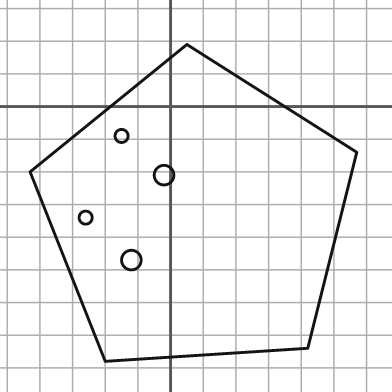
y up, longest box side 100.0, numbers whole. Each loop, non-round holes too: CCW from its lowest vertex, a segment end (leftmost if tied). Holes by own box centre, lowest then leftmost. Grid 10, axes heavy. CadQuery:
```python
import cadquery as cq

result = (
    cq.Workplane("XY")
    .moveTo(-20.0, -78.0)
    .lineTo(42.0, -74.0)
    .lineTo(57.0, -14.0)
    .lineTo(5.0, 19.0)
    .lineTo(-43.0, -20.0)
    .close()
    .moveTo(-12.0, -47.0)
    .circle(3.0)
    .moveTo(-26.0, -34.0)
    .circle(2.0)
    .moveTo(-2.0, -21.0)
    .circle(3.0)
    .moveTo(-15.0, -9.0)
    .circle(2.0)
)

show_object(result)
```